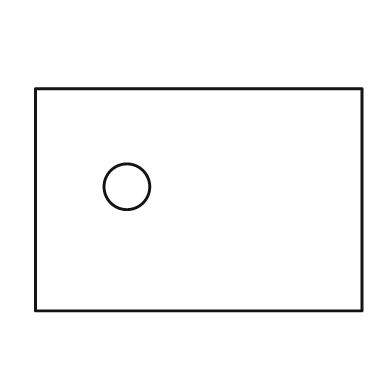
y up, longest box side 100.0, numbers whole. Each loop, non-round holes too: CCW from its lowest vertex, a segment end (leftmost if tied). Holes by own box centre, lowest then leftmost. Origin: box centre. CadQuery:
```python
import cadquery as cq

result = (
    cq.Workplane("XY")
    .moveTo(-50.0, -34.0)
    .lineTo(50.0, -34.0)
    .lineTo(50.0, 34.0)
    .lineTo(-50.0, 34.0)
    .close()
    .moveTo(-22.0, 4.0)
    .circle(7.0)
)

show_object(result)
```